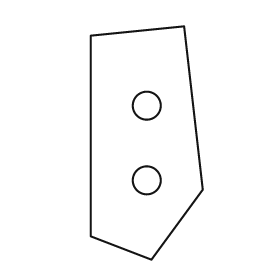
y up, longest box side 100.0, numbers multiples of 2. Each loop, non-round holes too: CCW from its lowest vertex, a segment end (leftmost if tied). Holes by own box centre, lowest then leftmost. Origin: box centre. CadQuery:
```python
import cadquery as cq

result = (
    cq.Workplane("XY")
    .moveTo(2.0, -50.0)
    .lineTo(24.0, -20.0)
    .lineTo(16.0, 50.0)
    .lineTo(-24.0, 46.0)
    .lineTo(-24.0, -40.0)
    .close()
    .moveTo(0.0, -16.0)
    .circle(6.0)
    .moveTo(0.0, 16.0)
    .circle(6.0)
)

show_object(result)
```